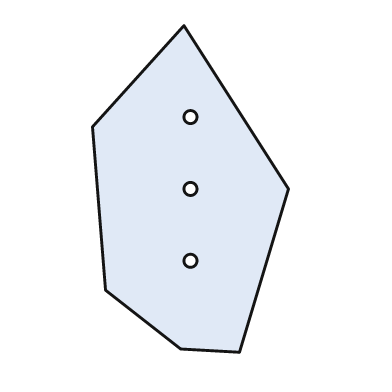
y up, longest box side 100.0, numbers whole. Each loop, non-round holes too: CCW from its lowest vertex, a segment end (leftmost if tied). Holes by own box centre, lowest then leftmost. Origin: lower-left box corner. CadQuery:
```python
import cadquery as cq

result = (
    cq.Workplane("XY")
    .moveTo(45.0, 0.0)
    .lineTo(60.0, 50.0)
    .lineTo(28.0, 100.0)
    .lineTo(0.0, 69.0)
    .lineTo(4.0, 19.0)
    .lineTo(27.0, 1.0)
    .close()
    .moveTo(30.0, 28.0)
    .circle(2.0)
    .moveTo(30.0, 50.0)
    .circle(2.0)
    .moveTo(30.0, 72.0)
    .circle(2.0)
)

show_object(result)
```